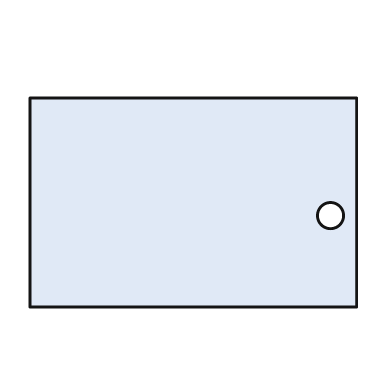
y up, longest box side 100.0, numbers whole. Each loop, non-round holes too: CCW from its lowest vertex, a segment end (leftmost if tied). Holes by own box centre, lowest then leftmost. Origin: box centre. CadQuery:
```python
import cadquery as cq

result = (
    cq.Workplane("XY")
    .moveTo(-50.0, -32.0)
    .lineTo(50.0, -32.0)
    .lineTo(50.0, 32.0)
    .lineTo(-50.0, 32.0)
    .close()
    .moveTo(42.0, -4.0)
    .circle(4.0)
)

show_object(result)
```